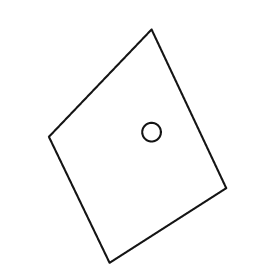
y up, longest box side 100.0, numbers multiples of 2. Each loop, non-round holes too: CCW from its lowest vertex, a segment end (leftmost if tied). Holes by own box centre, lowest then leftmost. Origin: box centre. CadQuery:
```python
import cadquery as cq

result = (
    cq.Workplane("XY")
    .moveTo(-12.0, -50.0)
    .lineTo(38.0, -18.0)
    .lineTo(6.0, 50.0)
    .lineTo(-38.0, 4.0)
    .close()
    .moveTo(6.0, 6.0)
    .circle(4.0)
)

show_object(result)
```